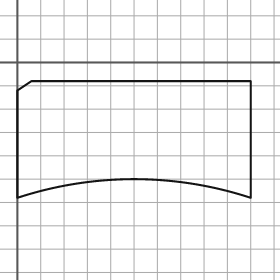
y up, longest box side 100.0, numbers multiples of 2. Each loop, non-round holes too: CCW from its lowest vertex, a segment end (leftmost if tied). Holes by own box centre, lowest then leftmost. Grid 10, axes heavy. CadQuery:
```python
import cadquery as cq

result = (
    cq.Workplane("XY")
    .moveTo(0.0, -58.0)
    .threePointArc((50.0, -50.0), (100.0, -58.0))
    .lineTo(100.0, -8.0)
    .lineTo(6.0, -8.0)
    .lineTo(0.0, -12.0)
    .close()
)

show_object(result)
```